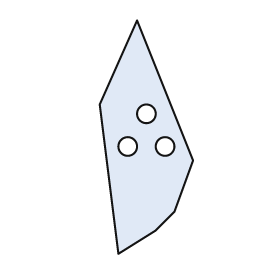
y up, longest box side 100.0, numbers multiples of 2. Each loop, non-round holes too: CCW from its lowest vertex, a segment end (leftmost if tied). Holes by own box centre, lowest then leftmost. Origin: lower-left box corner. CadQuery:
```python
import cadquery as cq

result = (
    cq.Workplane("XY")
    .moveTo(8.0, 0.0)
    .lineTo(24.0, 10.0)
    .lineTo(32.0, 18.0)
    .lineTo(40.0, 40.0)
    .lineTo(16.0, 100.0)
    .lineTo(0.0, 64.0)
    .close()
    .moveTo(12.0, 46.0)
    .circle(4.0)
    .moveTo(28.0, 46.0)
    .circle(4.0)
    .moveTo(20.0, 60.0)
    .circle(4.0)
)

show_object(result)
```